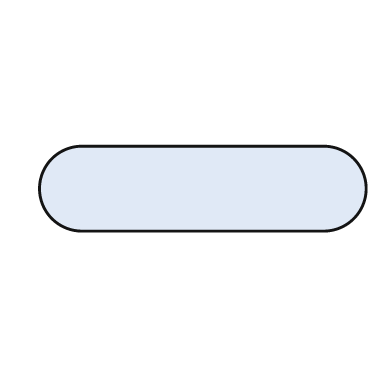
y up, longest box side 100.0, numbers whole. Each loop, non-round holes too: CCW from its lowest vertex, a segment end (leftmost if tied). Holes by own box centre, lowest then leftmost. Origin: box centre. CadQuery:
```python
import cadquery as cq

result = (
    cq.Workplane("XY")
    .moveTo(-37.0, -13.0)
    .lineTo(37.0, -13.0)
    .threePointArc((50.0, 0.0), (37.0, 13.0))
    .lineTo(-37.0, 13.0)
    .threePointArc((-50.0, 0.0), (-37.0, -13.0))
    .close()
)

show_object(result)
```